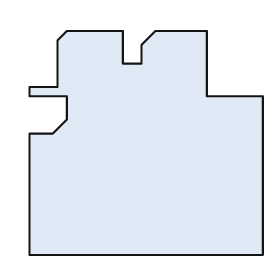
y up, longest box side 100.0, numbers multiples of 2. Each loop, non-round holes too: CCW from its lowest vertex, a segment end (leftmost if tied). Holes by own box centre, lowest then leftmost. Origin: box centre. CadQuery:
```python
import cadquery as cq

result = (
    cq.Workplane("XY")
    .moveTo(-50.0, -48.0)
    .lineTo(50.0, -48.0)
    .lineTo(50.0, 20.0)
    .lineTo(26.0, 20.0)
    .lineTo(26.0, 48.0)
    .lineTo(4.0, 48.0)
    .lineTo(-2.0, 42.0)
    .lineTo(-2.0, 34.0)
    .lineTo(-10.0, 34.0)
    .lineTo(-10.0, 48.0)
    .lineTo(-34.0, 48.0)
    .lineTo(-38.0, 44.0)
    .lineTo(-38.0, 24.0)
    .lineTo(-50.0, 24.0)
    .lineTo(-50.0, 20.0)
    .lineTo(-34.0, 20.0)
    .lineTo(-34.0, 10.0)
    .lineTo(-40.0, 4.0)
    .lineTo(-50.0, 4.0)
    .close()
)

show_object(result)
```